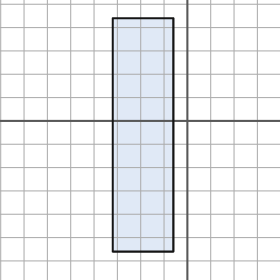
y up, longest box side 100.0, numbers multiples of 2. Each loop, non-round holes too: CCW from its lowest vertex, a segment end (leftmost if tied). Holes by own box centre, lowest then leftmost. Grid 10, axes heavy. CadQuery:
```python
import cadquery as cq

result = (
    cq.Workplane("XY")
    .moveTo(-32.0, -56.0)
    .lineTo(-6.0, -56.0)
    .lineTo(-6.0, 44.0)
    .lineTo(-32.0, 44.0)
    .close()
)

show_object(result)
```